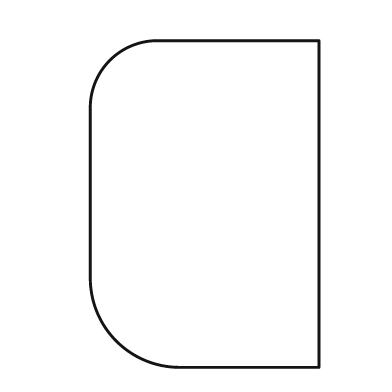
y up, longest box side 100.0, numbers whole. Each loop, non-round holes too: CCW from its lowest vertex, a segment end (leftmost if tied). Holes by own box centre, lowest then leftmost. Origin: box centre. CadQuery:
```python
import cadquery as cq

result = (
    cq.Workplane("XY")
    .moveTo(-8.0, -50.0)
    .lineTo(35.0, -50.0)
    .lineTo(35.0, 50.0)
    .lineTo(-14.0, 50.0)
    .threePointArc((-29.0, 44.0), (-35.0, 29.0))
    .lineTo(-35.0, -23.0)
    .threePointArc((-27.0, -42.0), (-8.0, -50.0))
    .close()
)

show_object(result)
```